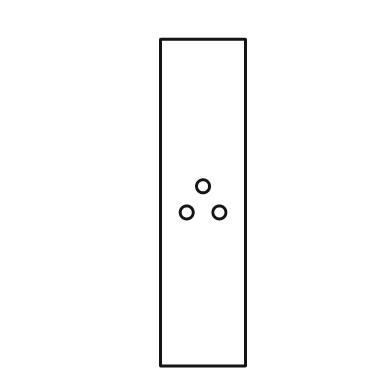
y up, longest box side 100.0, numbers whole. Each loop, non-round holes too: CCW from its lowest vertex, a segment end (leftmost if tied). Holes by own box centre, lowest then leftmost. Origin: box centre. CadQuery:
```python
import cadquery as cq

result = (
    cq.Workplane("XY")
    .moveTo(-13.0, -50.0)
    .lineTo(13.0, -50.0)
    .lineTo(13.0, 50.0)
    .lineTo(-13.0, 50.0)
    .close()
    .moveTo(-5.0, -3.0)
    .circle(2.0)
    .moveTo(5.0, -3.0)
    .circle(2.0)
    .moveTo(0.0, 5.0)
    .circle(2.0)
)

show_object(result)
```